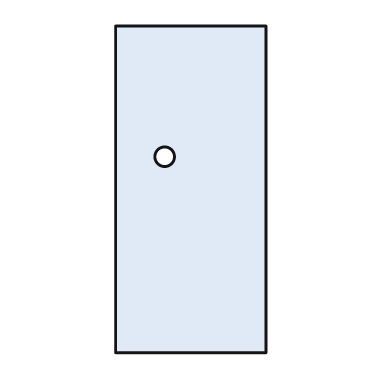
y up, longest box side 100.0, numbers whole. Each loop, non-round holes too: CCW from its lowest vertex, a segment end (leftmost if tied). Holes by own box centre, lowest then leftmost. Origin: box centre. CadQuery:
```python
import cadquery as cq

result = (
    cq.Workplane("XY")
    .moveTo(-23.0, -50.0)
    .lineTo(23.0, -50.0)
    .lineTo(23.0, 50.0)
    .lineTo(-23.0, 50.0)
    .close()
    .moveTo(-8.0, 10.0)
    .circle(3.0)
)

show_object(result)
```